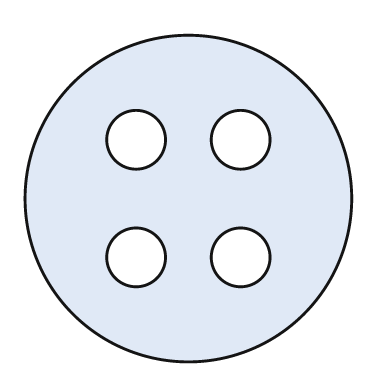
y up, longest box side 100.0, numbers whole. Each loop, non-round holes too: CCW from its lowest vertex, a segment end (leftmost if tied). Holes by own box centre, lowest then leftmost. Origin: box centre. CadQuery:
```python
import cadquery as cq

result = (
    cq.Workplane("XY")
    .moveTo(0.0, 0.0)
    .circle(50.0)
    .moveTo(-16.0, -18.0)
    .circle(9.0)
    .moveTo(16.0, -18.0)
    .circle(9.0)
    .moveTo(-16.0, 18.0)
    .circle(9.0)
    .moveTo(16.0, 18.0)
    .circle(9.0)
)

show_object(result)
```